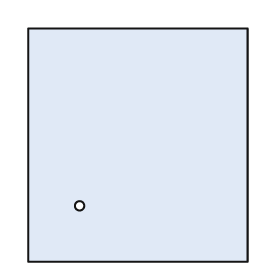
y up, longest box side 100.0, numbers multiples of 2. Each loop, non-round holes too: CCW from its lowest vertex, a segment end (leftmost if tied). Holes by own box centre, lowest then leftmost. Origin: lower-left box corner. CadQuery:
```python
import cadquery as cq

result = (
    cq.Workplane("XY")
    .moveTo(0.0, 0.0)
    .lineTo(94.0, 0.0)
    .lineTo(94.0, 100.0)
    .lineTo(0.0, 100.0)
    .close()
    .moveTo(22.0, 24.0)
    .circle(2.0)
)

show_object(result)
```